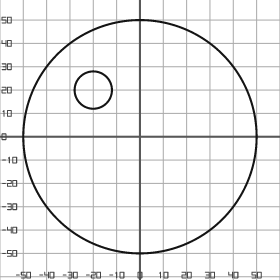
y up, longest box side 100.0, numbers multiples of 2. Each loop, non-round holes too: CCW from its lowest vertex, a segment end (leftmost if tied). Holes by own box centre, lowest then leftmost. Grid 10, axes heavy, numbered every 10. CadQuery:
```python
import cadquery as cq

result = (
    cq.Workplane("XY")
    .moveTo(0.0, 0.0)
    .circle(50.0)
    .moveTo(-20.0, 20.0)
    .circle(8.0)
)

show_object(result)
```